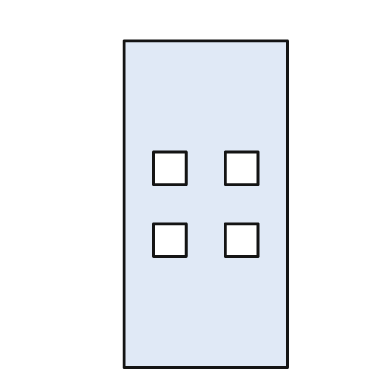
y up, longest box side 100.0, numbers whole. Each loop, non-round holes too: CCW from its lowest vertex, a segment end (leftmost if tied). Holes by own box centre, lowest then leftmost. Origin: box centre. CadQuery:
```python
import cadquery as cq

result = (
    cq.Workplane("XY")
    .moveTo(-25.0, -50.0)
    .lineTo(25.0, -50.0)
    .lineTo(25.0, 50.0)
    .lineTo(-25.0, 50.0)
    .close()
    .moveTo(-16.0, -16.0)
    .lineTo(-6.0, -16.0)
    .lineTo(-6.0, -6.0)
    .lineTo(-16.0, -6.0)
    .close()
    .moveTo(6.0, -16.0)
    .lineTo(16.0, -16.0)
    .lineTo(16.0, -6.0)
    .lineTo(6.0, -6.0)
    .close()
    .moveTo(-16.0, 6.0)
    .lineTo(-6.0, 6.0)
    .lineTo(-6.0, 16.0)
    .lineTo(-16.0, 16.0)
    .close()
    .moveTo(6.0, 6.0)
    .lineTo(16.0, 6.0)
    .lineTo(16.0, 16.0)
    .lineTo(6.0, 16.0)
    .close()
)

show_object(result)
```